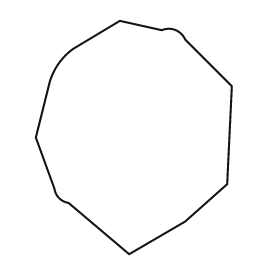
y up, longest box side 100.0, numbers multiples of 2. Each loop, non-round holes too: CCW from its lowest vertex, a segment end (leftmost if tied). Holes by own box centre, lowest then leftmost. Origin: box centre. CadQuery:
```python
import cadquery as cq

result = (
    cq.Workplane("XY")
    .moveTo(-2.0, -50.0)
    .lineTo(22.0, -36.0)
    .lineTo(40.0, -20.0)
    .lineTo(42.0, 22.0)
    .lineTo(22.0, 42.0)
    .threePointArc((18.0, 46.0), (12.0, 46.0))
    .lineTo(-6.0, 50.0)
    .lineTo(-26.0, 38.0)
    .threePointArc((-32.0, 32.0), (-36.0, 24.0))
    .lineTo(-42.0, 0.0)
    .lineTo(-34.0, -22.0)
    .threePointArc((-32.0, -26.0), (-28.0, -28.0))
    .close()
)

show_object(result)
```